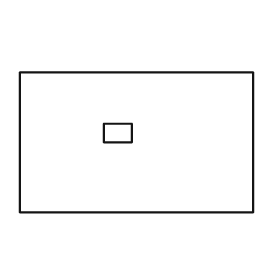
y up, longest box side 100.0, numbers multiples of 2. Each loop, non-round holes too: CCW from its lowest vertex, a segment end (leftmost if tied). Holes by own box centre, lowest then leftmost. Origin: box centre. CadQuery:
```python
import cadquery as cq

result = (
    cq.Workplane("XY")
    .moveTo(-50.0, -30.0)
    .lineTo(50.0, -30.0)
    .lineTo(50.0, 30.0)
    .lineTo(-50.0, 30.0)
    .close()
    .moveTo(-14.0, 0.0)
    .lineTo(-2.0, 0.0)
    .lineTo(-2.0, 8.0)
    .lineTo(-14.0, 8.0)
    .close()
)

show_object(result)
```